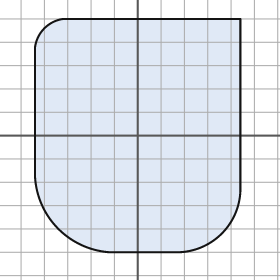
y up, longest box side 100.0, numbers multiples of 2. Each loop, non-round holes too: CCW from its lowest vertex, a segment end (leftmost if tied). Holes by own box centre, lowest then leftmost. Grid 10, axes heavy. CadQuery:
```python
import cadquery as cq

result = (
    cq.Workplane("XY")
    .moveTo(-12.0, -50.0)
    .lineTo(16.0, -50.0)
    .threePointArc((36.0, -42.0), (44.0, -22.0))
    .lineTo(44.0, 50.0)
    .lineTo(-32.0, 50.0)
    .threePointArc((-40.0, 46.0), (-44.0, 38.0))
    .lineTo(-44.0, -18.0)
    .threePointArc((-34.0, -40.0), (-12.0, -50.0))
    .close()
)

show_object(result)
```